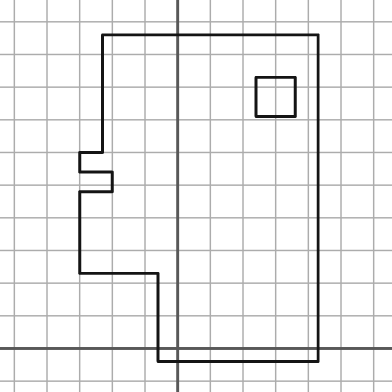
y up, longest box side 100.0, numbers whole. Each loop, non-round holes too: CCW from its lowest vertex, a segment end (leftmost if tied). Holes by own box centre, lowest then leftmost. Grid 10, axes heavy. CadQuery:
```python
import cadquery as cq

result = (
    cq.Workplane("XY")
    .moveTo(-6.0, -4.0)
    .lineTo(43.0, -4.0)
    .lineTo(43.0, 96.0)
    .lineTo(-23.0, 96.0)
    .lineTo(-23.0, 60.0)
    .lineTo(-30.0, 60.0)
    .lineTo(-30.0, 54.0)
    .lineTo(-20.0, 54.0)
    .lineTo(-20.0, 48.0)
    .lineTo(-30.0, 48.0)
    .lineTo(-30.0, 23.0)
    .lineTo(-6.0, 23.0)
    .close()
    .moveTo(24.0, 71.0)
    .lineTo(36.0, 71.0)
    .lineTo(36.0, 83.0)
    .lineTo(24.0, 83.0)
    .close()
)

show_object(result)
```